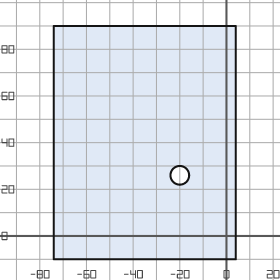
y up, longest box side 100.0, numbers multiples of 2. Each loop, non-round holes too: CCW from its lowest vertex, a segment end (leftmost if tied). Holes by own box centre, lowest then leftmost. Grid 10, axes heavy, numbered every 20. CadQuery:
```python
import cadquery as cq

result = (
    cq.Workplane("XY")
    .moveTo(-74.0, -10.0)
    .lineTo(4.0, -10.0)
    .lineTo(4.0, 90.0)
    .lineTo(-74.0, 90.0)
    .close()
    .moveTo(-20.0, 26.0)
    .circle(4.0)
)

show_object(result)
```